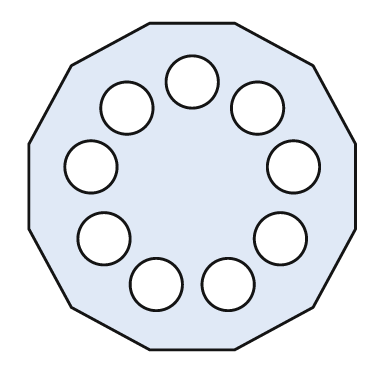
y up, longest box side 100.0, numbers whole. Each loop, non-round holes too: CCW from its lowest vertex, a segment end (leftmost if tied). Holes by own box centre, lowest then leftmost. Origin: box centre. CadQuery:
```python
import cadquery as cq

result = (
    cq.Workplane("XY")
    .moveTo(-13.0, -50.0)
    .lineTo(13.0, -50.0)
    .lineTo(37.0, -37.0)
    .lineTo(50.0, -13.0)
    .lineTo(50.0, 13.0)
    .lineTo(37.0, 37.0)
    .lineTo(13.0, 50.0)
    .lineTo(-13.0, 50.0)
    .lineTo(-37.0, 37.0)
    .lineTo(-50.0, 13.0)
    .lineTo(-50.0, -13.0)
    .lineTo(-37.0, -37.0)
    .close()
    .moveTo(-11.0, -30.0)
    .circle(8.0)
    .moveTo(11.0, -30.0)
    .circle(8.0)
    .moveTo(-27.0, -16.0)
    .circle(8.0)
    .moveTo(27.0, -16.0)
    .circle(8.0)
    .moveTo(-31.0, 6.0)
    .circle(8.0)
    .moveTo(31.0, 6.0)
    .circle(8.0)
    .moveTo(-20.0, 24.0)
    .circle(8.0)
    .moveTo(20.0, 24.0)
    .circle(8.0)
    .moveTo(0.0, 32.0)
    .circle(8.0)
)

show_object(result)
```